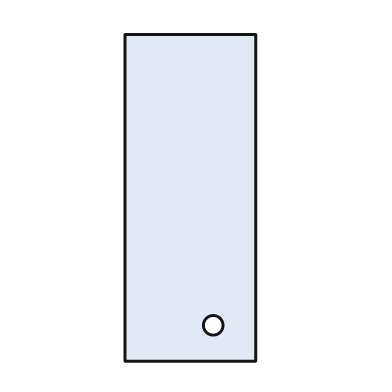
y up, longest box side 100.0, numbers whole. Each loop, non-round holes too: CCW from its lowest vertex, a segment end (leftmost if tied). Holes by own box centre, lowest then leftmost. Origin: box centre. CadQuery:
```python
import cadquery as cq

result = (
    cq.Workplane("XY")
    .moveTo(-20.0, -50.0)
    .lineTo(20.0, -50.0)
    .lineTo(20.0, 50.0)
    .lineTo(-20.0, 50.0)
    .close()
    .moveTo(7.0, -39.0)
    .circle(3.0)
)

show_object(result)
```